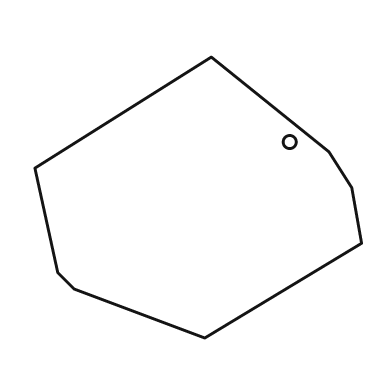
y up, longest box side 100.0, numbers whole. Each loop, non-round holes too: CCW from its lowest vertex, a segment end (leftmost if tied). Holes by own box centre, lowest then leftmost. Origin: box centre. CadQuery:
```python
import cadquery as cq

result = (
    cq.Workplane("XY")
    .moveTo(2.0, -43.0)
    .lineTo(50.0, -14.0)
    .lineTo(47.0, 3.0)
    .lineTo(40.0, 14.0)
    .lineTo(4.0, 43.0)
    .lineTo(-50.0, 9.0)
    .lineTo(-43.0, -23.0)
    .lineTo(-38.0, -28.0)
    .close()
    .moveTo(28.0, 17.0)
    .circle(2.0)
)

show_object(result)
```